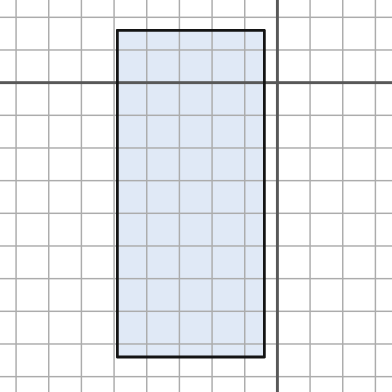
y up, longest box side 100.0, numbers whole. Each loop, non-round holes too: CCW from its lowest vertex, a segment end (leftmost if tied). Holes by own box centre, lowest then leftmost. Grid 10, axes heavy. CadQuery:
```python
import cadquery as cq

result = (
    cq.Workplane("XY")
    .moveTo(-49.0, -84.0)
    .lineTo(-4.0, -84.0)
    .lineTo(-4.0, 16.0)
    .lineTo(-49.0, 16.0)
    .close()
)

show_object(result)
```